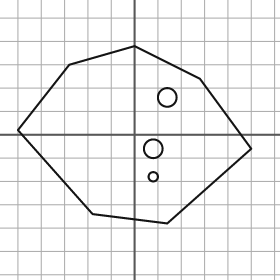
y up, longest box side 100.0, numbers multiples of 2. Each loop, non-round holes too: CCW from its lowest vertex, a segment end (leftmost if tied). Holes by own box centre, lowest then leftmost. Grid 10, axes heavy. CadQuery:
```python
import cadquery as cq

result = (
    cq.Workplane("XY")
    .moveTo(14.0, -38.0)
    .lineTo(50.0, -6.0)
    .lineTo(28.0, 24.0)
    .lineTo(0.0, 38.0)
    .lineTo(-28.0, 30.0)
    .lineTo(-50.0, 2.0)
    .lineTo(-18.0, -34.0)
    .close()
    .moveTo(8.0, -18.0)
    .circle(2.0)
    .moveTo(8.0, -6.0)
    .circle(4.0)
    .moveTo(14.0, 16.0)
    .circle(4.0)
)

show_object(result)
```